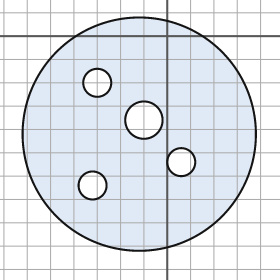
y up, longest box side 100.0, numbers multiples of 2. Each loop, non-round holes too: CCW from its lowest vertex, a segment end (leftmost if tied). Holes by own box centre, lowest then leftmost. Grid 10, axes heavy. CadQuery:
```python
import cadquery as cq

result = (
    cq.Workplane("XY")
    .moveTo(-12.0, -42.0)
    .circle(50.0)
    .moveTo(-32.0, -64.0)
    .circle(6.0)
    .moveTo(6.0, -54.0)
    .circle(6.0)
    .moveTo(-10.0, -36.0)
    .circle(8.0)
    .moveTo(-30.0, -20.0)
    .circle(6.0)
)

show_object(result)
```